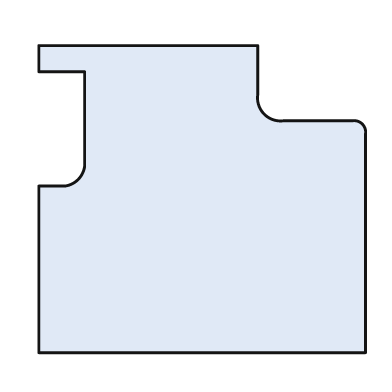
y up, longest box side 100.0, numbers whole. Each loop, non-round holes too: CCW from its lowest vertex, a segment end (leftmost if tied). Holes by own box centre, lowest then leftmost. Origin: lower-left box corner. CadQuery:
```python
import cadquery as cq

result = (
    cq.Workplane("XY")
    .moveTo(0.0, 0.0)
    .lineTo(100.0, 0.0)
    .lineTo(100.0, 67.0)
    .threePointArc((99.0, 70.0), (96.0, 71.0))
    .lineTo(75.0, 71.0)
    .threePointArc((69.0, 73.0), (67.0, 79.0))
    .lineTo(67.0, 94.0)
    .lineTo(0.0, 94.0)
    .lineTo(0.0, 86.0)
    .lineTo(14.0, 86.0)
    .lineTo(14.0, 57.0)
    .threePointArc((12.0, 53.0), (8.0, 51.0))
    .lineTo(0.0, 51.0)
    .close()
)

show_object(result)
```